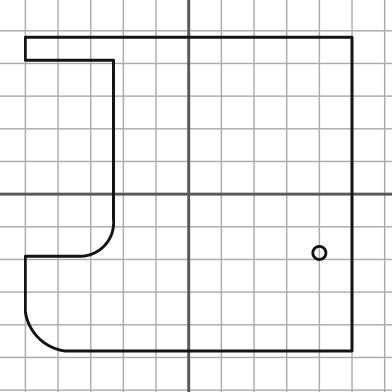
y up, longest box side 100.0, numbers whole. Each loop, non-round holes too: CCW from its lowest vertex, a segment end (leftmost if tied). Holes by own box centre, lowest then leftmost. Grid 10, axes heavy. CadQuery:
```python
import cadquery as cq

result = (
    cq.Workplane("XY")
    .moveTo(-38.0, -48.0)
    .lineTo(50.0, -48.0)
    .lineTo(50.0, 48.0)
    .lineTo(-50.0, 48.0)
    .lineTo(-50.0, 41.0)
    .lineTo(-23.0, 41.0)
    .lineTo(-23.0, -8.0)
    .threePointArc((-26.0, -16.0), (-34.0, -19.0))
    .lineTo(-50.0, -19.0)
    .lineTo(-50.0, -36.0)
    .threePointArc((-46.0, -44.0), (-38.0, -48.0))
    .close()
    .moveTo(40.0, -18.0)
    .circle(2.0)
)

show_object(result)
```